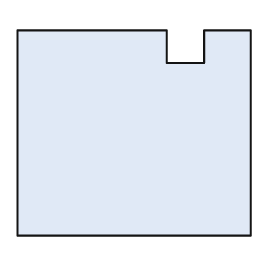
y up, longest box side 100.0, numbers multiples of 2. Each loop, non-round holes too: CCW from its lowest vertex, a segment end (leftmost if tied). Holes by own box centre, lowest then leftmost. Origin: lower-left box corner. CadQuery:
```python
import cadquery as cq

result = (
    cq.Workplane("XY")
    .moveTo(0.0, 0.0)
    .lineTo(100.0, 0.0)
    .lineTo(100.0, 88.0)
    .lineTo(80.0, 88.0)
    .lineTo(80.0, 74.0)
    .lineTo(64.0, 74.0)
    .lineTo(64.0, 88.0)
    .lineTo(0.0, 88.0)
    .close()
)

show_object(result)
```